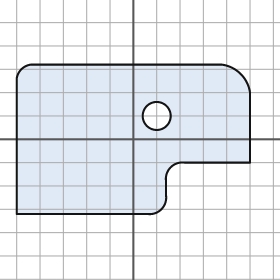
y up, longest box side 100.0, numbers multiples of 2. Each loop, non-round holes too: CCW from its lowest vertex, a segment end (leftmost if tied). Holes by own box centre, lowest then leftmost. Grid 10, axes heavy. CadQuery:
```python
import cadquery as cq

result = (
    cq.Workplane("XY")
    .moveTo(-50.0, -32.0)
    .lineTo(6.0, -32.0)
    .threePointArc((12.0, -30.0), (14.0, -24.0))
    .lineTo(14.0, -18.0)
    .threePointArc((16.0, -12.0), (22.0, -10.0))
    .lineTo(50.0, -10.0)
    .lineTo(50.0, 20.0)
    .threePointArc((46.0, 28.0), (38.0, 32.0))
    .lineTo(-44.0, 32.0)
    .threePointArc((-48.0, 30.0), (-50.0, 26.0))
    .close()
    .moveTo(10.0, 10.0)
    .circle(6.0)
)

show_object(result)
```